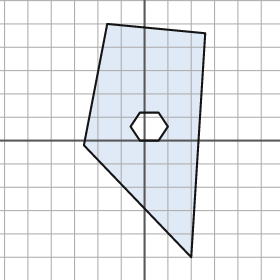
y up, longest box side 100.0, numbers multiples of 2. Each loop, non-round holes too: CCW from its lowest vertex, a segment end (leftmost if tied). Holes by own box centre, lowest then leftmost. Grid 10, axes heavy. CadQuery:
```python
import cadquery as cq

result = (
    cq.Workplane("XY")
    .moveTo(20.0, -50.0)
    .lineTo(26.0, 46.0)
    .lineTo(-16.0, 50.0)
    .lineTo(-26.0, -2.0)
    .close()
    .moveTo(-2.0, 0.0)
    .lineTo(6.0, 0.0)
    .lineTo(10.0, 6.0)
    .lineTo(6.0, 12.0)
    .lineTo(-2.0, 12.0)
    .lineTo(-6.0, 6.0)
    .close()
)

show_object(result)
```